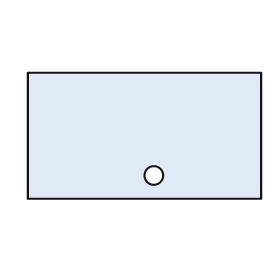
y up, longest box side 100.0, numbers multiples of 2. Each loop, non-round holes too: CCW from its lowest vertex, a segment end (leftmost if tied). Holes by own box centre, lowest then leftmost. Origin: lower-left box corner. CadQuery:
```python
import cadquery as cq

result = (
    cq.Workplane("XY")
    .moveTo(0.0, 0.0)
    .lineTo(100.0, 0.0)
    .lineTo(100.0, 54.0)
    .lineTo(0.0, 54.0)
    .close()
    .moveTo(54.0, 10.0)
    .circle(4.0)
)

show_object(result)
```